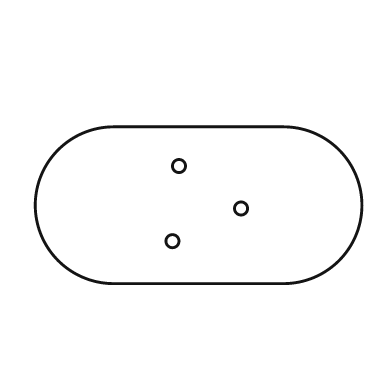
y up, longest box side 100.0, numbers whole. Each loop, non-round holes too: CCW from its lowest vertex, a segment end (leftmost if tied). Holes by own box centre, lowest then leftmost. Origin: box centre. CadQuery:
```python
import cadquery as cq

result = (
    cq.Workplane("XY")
    .moveTo(-26.0, -24.0)
    .lineTo(26.0, -24.0)
    .threePointArc((50.0, 0.0), (26.0, 24.0))
    .lineTo(-26.0, 24.0)
    .threePointArc((-50.0, 0.0), (-26.0, -24.0))
    .close()
    .moveTo(-8.0, -11.0)
    .circle(2.0)
    .moveTo(13.0, -1.0)
    .circle(2.0)
    .moveTo(-6.0, 12.0)
    .circle(2.0)
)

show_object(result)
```